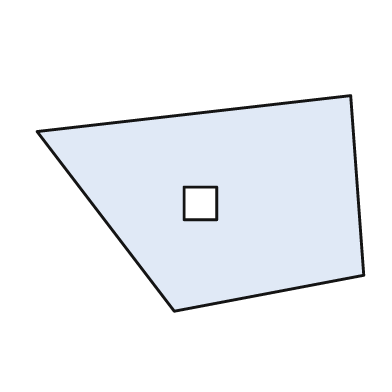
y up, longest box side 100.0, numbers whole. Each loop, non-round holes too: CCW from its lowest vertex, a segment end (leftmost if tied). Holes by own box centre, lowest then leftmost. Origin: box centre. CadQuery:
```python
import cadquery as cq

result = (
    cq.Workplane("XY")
    .moveTo(-8.0, -33.0)
    .lineTo(50.0, -22.0)
    .lineTo(46.0, 33.0)
    .lineTo(-50.0, 22.0)
    .close()
    .moveTo(-5.0, -5.0)
    .lineTo(5.0, -5.0)
    .lineTo(5.0, 5.0)
    .lineTo(-5.0, 5.0)
    .close()
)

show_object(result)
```